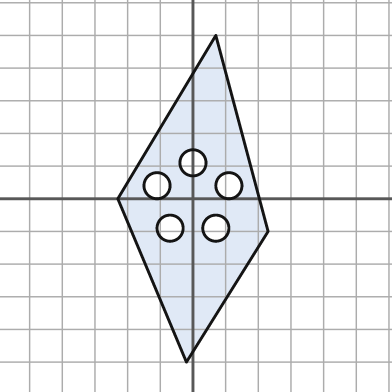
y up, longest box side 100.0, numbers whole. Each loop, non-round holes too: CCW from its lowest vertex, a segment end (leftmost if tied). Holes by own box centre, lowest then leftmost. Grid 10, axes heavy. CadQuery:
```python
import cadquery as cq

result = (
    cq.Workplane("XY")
    .moveTo(-2.0, -50.0)
    .lineTo(23.0, -10.0)
    .lineTo(7.0, 50.0)
    .lineTo(-23.0, 0.0)
    .close()
    .moveTo(-7.0, -9.0)
    .circle(4.0)
    .moveTo(7.0, -9.0)
    .circle(4.0)
    .moveTo(-11.0, 4.0)
    .circle(4.0)
    .moveTo(11.0, 4.0)
    .circle(4.0)
    .moveTo(0.0, 11.0)
    .circle(4.0)
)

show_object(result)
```